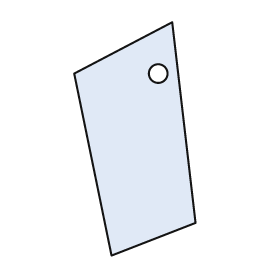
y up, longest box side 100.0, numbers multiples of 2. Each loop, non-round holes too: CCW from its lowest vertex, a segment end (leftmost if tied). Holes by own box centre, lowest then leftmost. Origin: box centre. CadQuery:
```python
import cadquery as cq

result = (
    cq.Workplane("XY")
    .moveTo(-10.0, -50.0)
    .lineTo(26.0, -36.0)
    .lineTo(16.0, 50.0)
    .lineTo(-26.0, 28.0)
    .close()
    .moveTo(10.0, 28.0)
    .circle(4.0)
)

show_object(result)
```